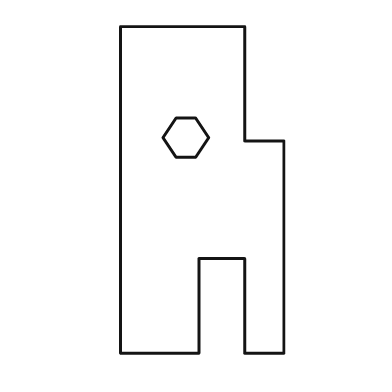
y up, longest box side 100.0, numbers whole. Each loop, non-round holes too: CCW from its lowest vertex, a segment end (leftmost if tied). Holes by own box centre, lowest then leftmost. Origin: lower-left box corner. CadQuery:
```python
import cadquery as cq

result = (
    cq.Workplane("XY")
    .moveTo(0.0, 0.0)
    .lineTo(24.0, 0.0)
    .lineTo(24.0, 29.0)
    .lineTo(38.0, 29.0)
    .lineTo(38.0, 0.0)
    .lineTo(50.0, 0.0)
    .lineTo(50.0, 65.0)
    .lineTo(38.0, 65.0)
    .lineTo(38.0, 100.0)
    .lineTo(0.0, 100.0)
    .close()
    .moveTo(17.0, 60.0)
    .lineTo(23.0, 60.0)
    .lineTo(27.0, 66.0)
    .lineTo(23.0, 72.0)
    .lineTo(17.0, 72.0)
    .lineTo(13.0, 66.0)
    .close()
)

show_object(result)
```